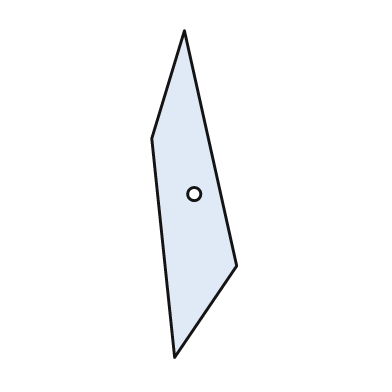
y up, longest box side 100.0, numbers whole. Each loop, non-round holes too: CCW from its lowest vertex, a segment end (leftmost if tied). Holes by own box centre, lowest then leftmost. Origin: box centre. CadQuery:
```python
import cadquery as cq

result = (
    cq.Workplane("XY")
    .moveTo(-6.0, -50.0)
    .lineTo(13.0, -22.0)
    .lineTo(-3.0, 50.0)
    .lineTo(-13.0, 17.0)
    .close()
    .moveTo(0.0, 0.0)
    .circle(2.0)
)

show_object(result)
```